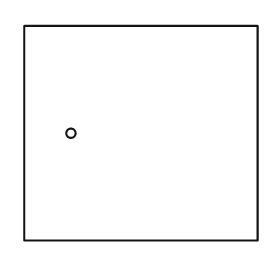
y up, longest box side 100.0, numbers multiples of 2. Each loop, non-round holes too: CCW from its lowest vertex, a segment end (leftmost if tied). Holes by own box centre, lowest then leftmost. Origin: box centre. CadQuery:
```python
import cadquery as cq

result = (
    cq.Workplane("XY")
    .moveTo(-50.0, -46.0)
    .lineTo(50.0, -46.0)
    .lineTo(50.0, 46.0)
    .lineTo(-50.0, 46.0)
    .close()
    .moveTo(-30.0, 0.0)
    .circle(2.0)
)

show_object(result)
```